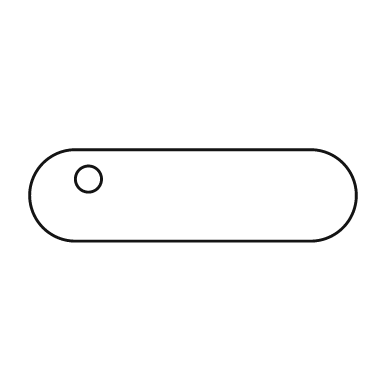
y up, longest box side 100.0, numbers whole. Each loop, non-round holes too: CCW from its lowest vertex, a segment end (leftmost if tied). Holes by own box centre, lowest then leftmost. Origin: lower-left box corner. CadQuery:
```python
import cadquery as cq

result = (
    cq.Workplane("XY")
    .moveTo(14.0, 0.0)
    .lineTo(86.0, 0.0)
    .threePointArc((100.0, 14.0), (86.0, 28.0))
    .lineTo(14.0, 28.0)
    .threePointArc((0.0, 14.0), (14.0, 0.0))
    .close()
    .moveTo(18.0, 19.0)
    .circle(4.0)
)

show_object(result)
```